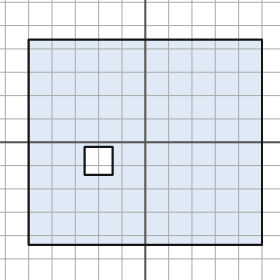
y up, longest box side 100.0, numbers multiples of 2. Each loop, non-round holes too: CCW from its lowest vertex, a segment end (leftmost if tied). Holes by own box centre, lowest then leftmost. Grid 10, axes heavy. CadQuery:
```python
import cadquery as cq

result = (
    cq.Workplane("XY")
    .moveTo(-50.0, -44.0)
    .lineTo(50.0, -44.0)
    .lineTo(50.0, 44.0)
    .lineTo(-50.0, 44.0)
    .close()
    .moveTo(-26.0, -14.0)
    .lineTo(-14.0, -14.0)
    .lineTo(-14.0, -2.0)
    .lineTo(-26.0, -2.0)
    .close()
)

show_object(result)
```